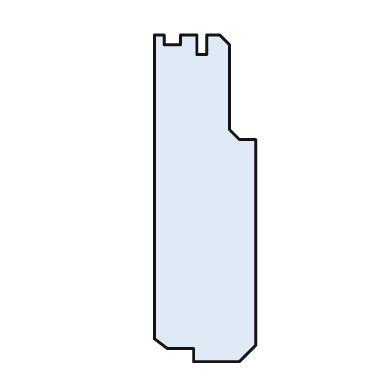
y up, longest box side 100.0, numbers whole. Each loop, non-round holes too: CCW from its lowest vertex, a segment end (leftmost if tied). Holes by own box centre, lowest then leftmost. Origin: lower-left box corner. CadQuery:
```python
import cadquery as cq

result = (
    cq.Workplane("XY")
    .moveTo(12.0, 0.0)
    .lineTo(26.0, 0.0)
    .lineTo(31.0, 5.0)
    .lineTo(31.0, 68.0)
    .lineTo(26.0, 68.0)
    .lineTo(23.0, 71.0)
    .lineTo(23.0, 97.0)
    .lineTo(20.0, 100.0)
    .lineTo(16.0, 100.0)
    .lineTo(16.0, 94.0)
    .lineTo(13.0, 94.0)
    .lineTo(13.0, 100.0)
    .lineTo(8.0, 100.0)
    .lineTo(8.0, 97.0)
    .lineTo(3.0, 97.0)
    .lineTo(3.0, 100.0)
    .lineTo(0.0, 100.0)
    .lineTo(0.0, 7.0)
    .lineTo(4.0, 4.0)
    .lineTo(12.0, 4.0)
    .close()
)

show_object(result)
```